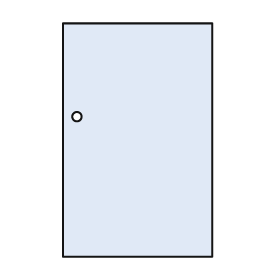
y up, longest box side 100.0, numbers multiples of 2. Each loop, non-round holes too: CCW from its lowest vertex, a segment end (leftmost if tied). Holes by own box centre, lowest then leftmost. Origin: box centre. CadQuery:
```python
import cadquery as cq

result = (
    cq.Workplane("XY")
    .moveTo(-32.0, -50.0)
    .lineTo(32.0, -50.0)
    .lineTo(32.0, 50.0)
    .lineTo(-32.0, 50.0)
    .close()
    .moveTo(-26.0, 10.0)
    .circle(2.0)
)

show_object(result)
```